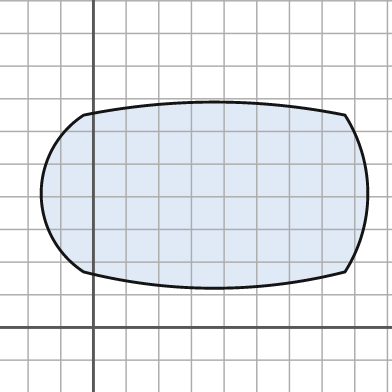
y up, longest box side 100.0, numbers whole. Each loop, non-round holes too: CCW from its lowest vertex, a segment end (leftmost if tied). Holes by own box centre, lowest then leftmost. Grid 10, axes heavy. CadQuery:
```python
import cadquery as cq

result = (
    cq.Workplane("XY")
    .moveTo(-3.0, 17.0)
    .threePointArc((37.0, 12.0), (77.0, 17.0))
    .threePointArc((84.0, 41.0), (77.0, 65.0))
    .threePointArc((37.0, 69.0), (-3.0, 65.0))
    .threePointArc((-16.0, 41.0), (-3.0, 17.0))
    .close()
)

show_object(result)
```